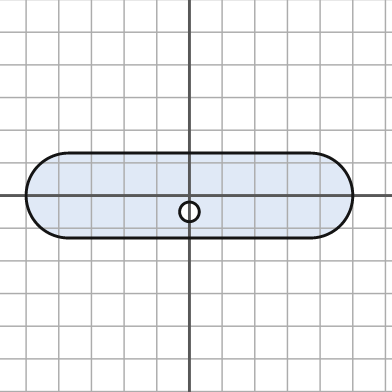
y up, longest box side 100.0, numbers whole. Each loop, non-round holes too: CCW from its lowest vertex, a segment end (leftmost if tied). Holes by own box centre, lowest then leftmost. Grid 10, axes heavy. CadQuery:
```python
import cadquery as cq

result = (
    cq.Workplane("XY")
    .moveTo(-37.0, -13.0)
    .lineTo(37.0, -13.0)
    .threePointArc((50.0, 0.0), (37.0, 13.0))
    .lineTo(-37.0, 13.0)
    .threePointArc((-50.0, 0.0), (-37.0, -13.0))
    .close()
    .moveTo(0.0, -5.0)
    .circle(3.0)
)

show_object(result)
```